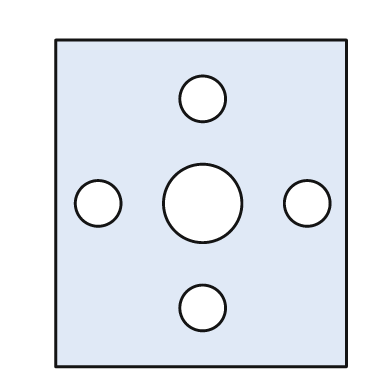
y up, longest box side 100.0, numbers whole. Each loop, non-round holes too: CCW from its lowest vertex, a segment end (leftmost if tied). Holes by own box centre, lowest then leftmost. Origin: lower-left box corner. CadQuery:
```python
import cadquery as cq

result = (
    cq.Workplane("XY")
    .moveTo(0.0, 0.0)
    .lineTo(89.0, 0.0)
    .lineTo(89.0, 100.0)
    .lineTo(0.0, 100.0)
    .close()
    .moveTo(45.0, 18.0)
    .circle(7.0)
    .moveTo(13.0, 50.0)
    .circle(7.0)
    .moveTo(45.0, 50.0)
    .circle(12.0)
    .moveTo(77.0, 50.0)
    .circle(7.0)
    .moveTo(45.0, 82.0)
    .circle(7.0)
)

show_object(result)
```